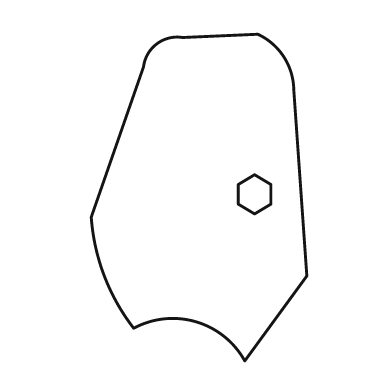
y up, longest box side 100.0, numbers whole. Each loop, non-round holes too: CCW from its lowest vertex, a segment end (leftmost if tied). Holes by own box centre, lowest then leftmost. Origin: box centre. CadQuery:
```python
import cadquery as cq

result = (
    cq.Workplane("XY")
    .moveTo(14.0, -50.0)
    .lineTo(33.0, -24.0)
    .lineTo(29.0, 33.0)
    .threePointArc((26.0, 43.0), (18.0, 50.0))
    .lineTo(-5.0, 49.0)
    .threePointArc((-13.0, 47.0), (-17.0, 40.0))
    .lineTo(-33.0, -6.0)
    .threePointArc((-29.0, -24.0), (-20.0, -40.0))
    .threePointArc((-1.0, -38.0), (14.0, -50.0))
    .close()
    .moveTo(17.0, -5.0)
    .lineTo(22.0, -2.0)
    .lineTo(22.0, 4.0)
    .lineTo(17.0, 7.0)
    .lineTo(12.0, 4.0)
    .lineTo(12.0, -2.0)
    .close()
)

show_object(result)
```